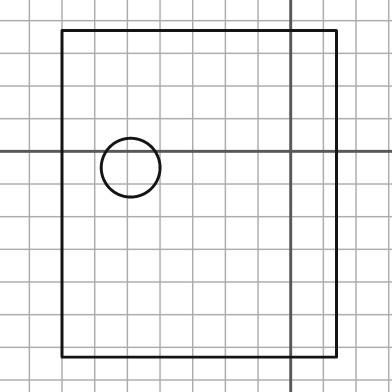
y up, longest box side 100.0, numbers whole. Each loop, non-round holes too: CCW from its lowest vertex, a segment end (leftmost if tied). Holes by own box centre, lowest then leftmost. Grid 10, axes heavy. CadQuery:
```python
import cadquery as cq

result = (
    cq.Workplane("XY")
    .moveTo(-70.0, -63.0)
    .lineTo(14.0, -63.0)
    .lineTo(14.0, 37.0)
    .lineTo(-70.0, 37.0)
    .close()
    .moveTo(-49.0, -5.0)
    .circle(9.0)
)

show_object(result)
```